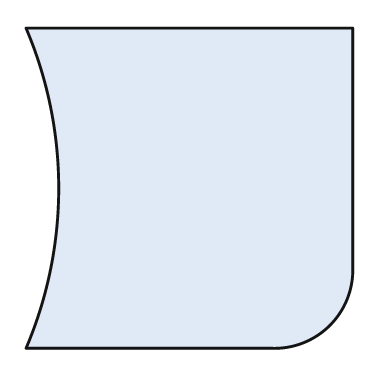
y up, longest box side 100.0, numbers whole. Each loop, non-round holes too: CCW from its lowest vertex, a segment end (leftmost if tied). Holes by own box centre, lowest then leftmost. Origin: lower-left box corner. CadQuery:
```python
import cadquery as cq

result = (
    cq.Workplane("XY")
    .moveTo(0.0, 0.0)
    .lineTo(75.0, 0.0)
    .threePointArc((93.0, 7.0), (100.0, 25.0))
    .lineTo(100.0, 98.0)
    .lineTo(0.0, 98.0)
    .threePointArc((10.0, 49.0), (0.0, 0.0))
    .close()
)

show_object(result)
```